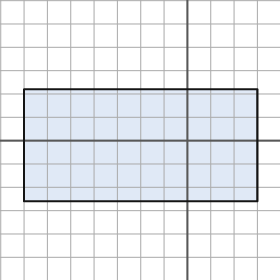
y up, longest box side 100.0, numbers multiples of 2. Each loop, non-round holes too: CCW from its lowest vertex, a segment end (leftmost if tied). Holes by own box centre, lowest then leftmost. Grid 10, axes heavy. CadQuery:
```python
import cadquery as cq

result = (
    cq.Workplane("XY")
    .moveTo(-70.0, -26.0)
    .lineTo(30.0, -26.0)
    .lineTo(30.0, 22.0)
    .lineTo(-70.0, 22.0)
    .close()
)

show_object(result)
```